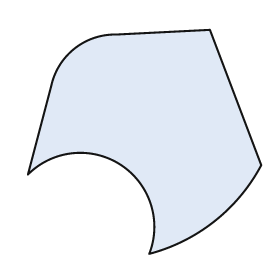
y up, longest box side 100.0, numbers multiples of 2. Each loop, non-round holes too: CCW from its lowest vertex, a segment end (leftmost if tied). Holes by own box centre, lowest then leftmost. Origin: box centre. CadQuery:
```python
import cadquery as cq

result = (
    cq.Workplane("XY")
    .moveTo(2.0, -48.0)
    .threePointArc((30.0, -34.0), (50.0, -10.0))
    .lineTo(28.0, 48.0)
    .lineTo(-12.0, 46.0)
    .threePointArc((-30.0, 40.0), (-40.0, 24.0))
    .lineTo(-50.0, -14.0)
    .threePointArc((-10.0, -10.0), (2.0, -48.0))
    .close()
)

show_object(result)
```